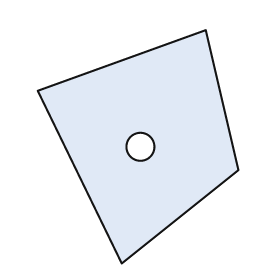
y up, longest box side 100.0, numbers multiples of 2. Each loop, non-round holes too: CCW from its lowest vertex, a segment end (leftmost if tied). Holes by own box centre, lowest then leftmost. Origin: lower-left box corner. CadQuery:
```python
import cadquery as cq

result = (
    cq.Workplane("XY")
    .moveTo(36.0, 0.0)
    .lineTo(86.0, 40.0)
    .lineTo(72.0, 100.0)
    .lineTo(0.0, 74.0)
    .close()
    .moveTo(44.0, 50.0)
    .circle(6.0)
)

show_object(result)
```